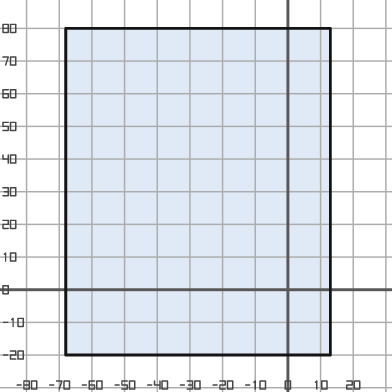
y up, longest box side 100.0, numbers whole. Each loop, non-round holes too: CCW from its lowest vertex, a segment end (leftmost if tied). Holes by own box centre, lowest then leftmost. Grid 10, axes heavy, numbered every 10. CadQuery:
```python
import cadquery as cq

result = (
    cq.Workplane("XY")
    .moveTo(-68.0, -20.0)
    .lineTo(13.0, -20.0)
    .lineTo(13.0, 80.0)
    .lineTo(-68.0, 80.0)
    .close()
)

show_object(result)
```